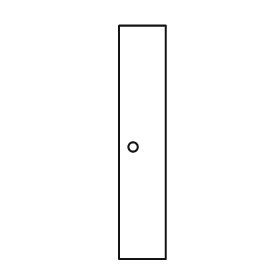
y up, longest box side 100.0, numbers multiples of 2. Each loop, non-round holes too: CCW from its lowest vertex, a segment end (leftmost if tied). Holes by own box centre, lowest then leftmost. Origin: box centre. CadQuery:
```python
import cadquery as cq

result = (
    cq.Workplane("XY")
    .moveTo(-10.0, -50.0)
    .lineTo(10.0, -50.0)
    .lineTo(10.0, 50.0)
    .lineTo(-10.0, 50.0)
    .close()
    .moveTo(-4.0, -2.0)
    .circle(2.0)
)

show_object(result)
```